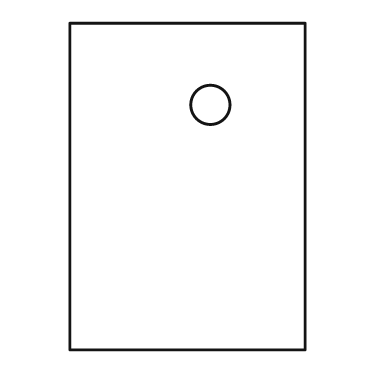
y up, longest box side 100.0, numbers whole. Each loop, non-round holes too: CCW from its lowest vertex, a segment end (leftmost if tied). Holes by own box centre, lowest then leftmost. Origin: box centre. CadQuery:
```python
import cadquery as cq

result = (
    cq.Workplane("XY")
    .moveTo(-36.0, -50.0)
    .lineTo(36.0, -50.0)
    .lineTo(36.0, 50.0)
    .lineTo(-36.0, 50.0)
    .close()
    .moveTo(7.0, 25.0)
    .circle(6.0)
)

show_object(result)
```